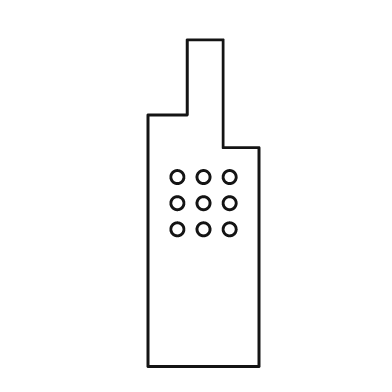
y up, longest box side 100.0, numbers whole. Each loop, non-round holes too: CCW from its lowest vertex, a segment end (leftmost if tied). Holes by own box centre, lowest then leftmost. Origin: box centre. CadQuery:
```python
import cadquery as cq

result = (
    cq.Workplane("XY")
    .moveTo(-17.0, -50.0)
    .lineTo(17.0, -50.0)
    .lineTo(17.0, 17.0)
    .lineTo(6.0, 17.0)
    .lineTo(6.0, 50.0)
    .lineTo(-5.0, 50.0)
    .lineTo(-5.0, 27.0)
    .lineTo(-17.0, 27.0)
    .close()
    .moveTo(-8.0, -8.0)
    .circle(2.0)
    .moveTo(0.0, -8.0)
    .circle(2.0)
    .moveTo(8.0, -8.0)
    .circle(2.0)
    .moveTo(-8.0, 0.0)
    .circle(2.0)
    .moveTo(0.0, 0.0)
    .circle(2.0)
    .moveTo(8.0, 0.0)
    .circle(2.0)
    .moveTo(-8.0, 8.0)
    .circle(2.0)
    .moveTo(0.0, 8.0)
    .circle(2.0)
    .moveTo(8.0, 8.0)
    .circle(2.0)
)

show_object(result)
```